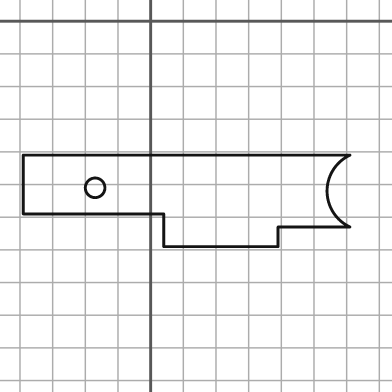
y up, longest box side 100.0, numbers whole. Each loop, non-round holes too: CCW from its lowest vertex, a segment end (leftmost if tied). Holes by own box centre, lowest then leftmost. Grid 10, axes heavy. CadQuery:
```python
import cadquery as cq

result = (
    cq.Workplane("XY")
    .moveTo(4.0, -69.0)
    .lineTo(39.0, -69.0)
    .lineTo(39.0, -63.0)
    .lineTo(61.0, -63.0)
    .threePointArc((54.0, -52.0), (61.0, -41.0))
    .lineTo(-39.0, -41.0)
    .lineTo(-39.0, -59.0)
    .lineTo(4.0, -59.0)
    .close()
    .moveTo(-17.0, -51.0)
    .circle(3.0)
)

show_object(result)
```